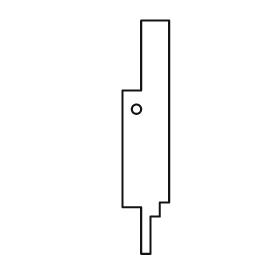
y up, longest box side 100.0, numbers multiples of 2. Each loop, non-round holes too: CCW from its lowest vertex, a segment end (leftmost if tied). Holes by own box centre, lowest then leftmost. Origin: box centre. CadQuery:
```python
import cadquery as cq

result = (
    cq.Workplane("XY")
    .moveTo(-2.0, -50.0)
    .lineTo(2.0, -50.0)
    .lineTo(2.0, -34.0)
    .lineTo(6.0, -34.0)
    .lineTo(6.0, -28.0)
    .lineTo(10.0, -28.0)
    .lineTo(10.0, 50.0)
    .lineTo(-2.0, 50.0)
    .lineTo(-2.0, 20.0)
    .lineTo(-10.0, 20.0)
    .lineTo(-10.0, -30.0)
    .lineTo(-2.0, -30.0)
    .close()
    .moveTo(-4.0, 12.0)
    .circle(2.0)
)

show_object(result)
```